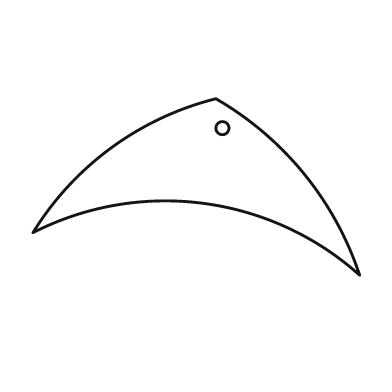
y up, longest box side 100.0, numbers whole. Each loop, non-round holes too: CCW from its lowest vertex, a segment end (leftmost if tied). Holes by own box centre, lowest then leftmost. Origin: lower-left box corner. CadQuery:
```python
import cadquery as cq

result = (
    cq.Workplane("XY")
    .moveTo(100.0, 0.0)
    .threePointArc((83.0, 31.0), (56.0, 54.0))
    .threePointArc((24.0, 39.0), (0.0, 13.0))
    .threePointArc((52.0, 22.0), (100.0, 0.0))
    .close()
    .moveTo(58.0, 45.0)
    .circle(2.0)
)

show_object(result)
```